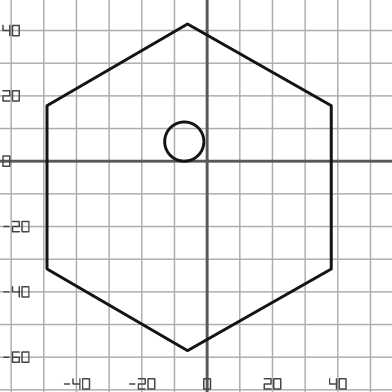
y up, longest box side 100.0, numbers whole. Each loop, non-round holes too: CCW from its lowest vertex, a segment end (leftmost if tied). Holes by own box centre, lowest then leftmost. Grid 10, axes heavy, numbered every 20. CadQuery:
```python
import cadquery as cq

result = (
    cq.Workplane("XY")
    .moveTo(-6.0, -58.0)
    .lineTo(38.0, -33.0)
    .lineTo(38.0, 17.0)
    .lineTo(-6.0, 42.0)
    .lineTo(-49.0, 17.0)
    .lineTo(-49.0, -33.0)
    .close()
    .moveTo(-7.0, 6.0)
    .circle(6.0)
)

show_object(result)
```